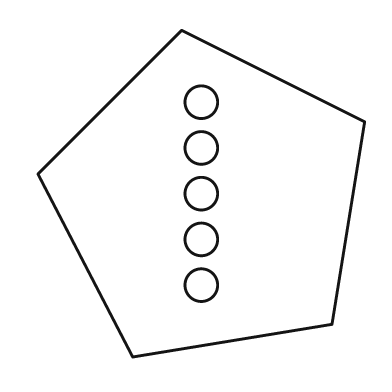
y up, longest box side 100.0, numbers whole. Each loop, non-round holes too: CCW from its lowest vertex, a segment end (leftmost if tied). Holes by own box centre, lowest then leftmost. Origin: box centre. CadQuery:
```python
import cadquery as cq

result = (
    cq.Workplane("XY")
    .moveTo(-21.0, -50.0)
    .lineTo(40.0, -40.0)
    .lineTo(50.0, 22.0)
    .lineTo(-6.0, 50.0)
    .lineTo(-50.0, 6.0)
    .close()
    .moveTo(0.0, -28.0)
    .circle(5.0)
    .moveTo(0.0, -14.0)
    .circle(5.0)
    .moveTo(0.0, 0.0)
    .circle(5.0)
    .moveTo(0.0, 14.0)
    .circle(5.0)
    .moveTo(0.0, 28.0)
    .circle(5.0)
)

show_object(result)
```